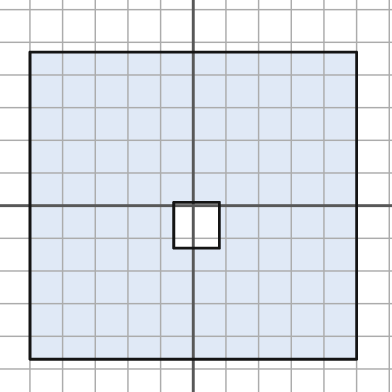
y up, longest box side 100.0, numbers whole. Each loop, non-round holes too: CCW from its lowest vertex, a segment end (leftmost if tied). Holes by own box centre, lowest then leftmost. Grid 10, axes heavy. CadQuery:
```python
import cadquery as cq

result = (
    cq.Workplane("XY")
    .moveTo(-50.0, -47.0)
    .lineTo(50.0, -47.0)
    .lineTo(50.0, 47.0)
    .lineTo(-50.0, 47.0)
    .close()
    .moveTo(-6.0, -13.0)
    .lineTo(8.0, -13.0)
    .lineTo(8.0, 1.0)
    .lineTo(-6.0, 1.0)
    .close()
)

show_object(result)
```